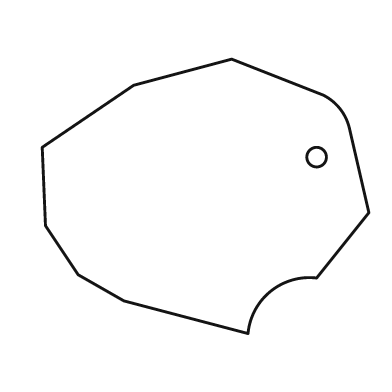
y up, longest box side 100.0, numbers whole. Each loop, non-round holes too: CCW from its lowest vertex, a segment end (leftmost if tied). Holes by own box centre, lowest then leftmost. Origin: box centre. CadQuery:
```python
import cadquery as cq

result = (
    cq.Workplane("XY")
    .moveTo(13.0, -42.0)
    .threePointArc((20.0, -29.0), (34.0, -25.0))
    .lineTo(50.0, -5.0)
    .lineTo(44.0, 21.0)
    .threePointArc((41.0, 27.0), (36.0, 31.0))
    .lineTo(8.0, 42.0)
    .lineTo(-22.0, 34.0)
    .lineTo(-50.0, 15.0)
    .lineTo(-49.0, -9.0)
    .lineTo(-39.0, -24.0)
    .lineTo(-25.0, -32.0)
    .close()
    .moveTo(34.0, 12.0)
    .circle(3.0)
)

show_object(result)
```